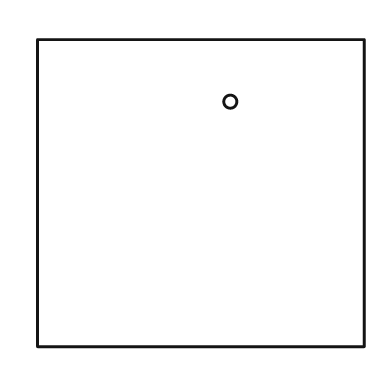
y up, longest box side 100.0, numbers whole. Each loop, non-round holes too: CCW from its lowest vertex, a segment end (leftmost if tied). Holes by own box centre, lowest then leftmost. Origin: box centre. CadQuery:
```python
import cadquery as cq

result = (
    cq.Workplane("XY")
    .moveTo(-50.0, -47.0)
    .lineTo(50.0, -47.0)
    .lineTo(50.0, 47.0)
    .lineTo(-50.0, 47.0)
    .close()
    .moveTo(9.0, 28.0)
    .circle(2.0)
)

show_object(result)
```